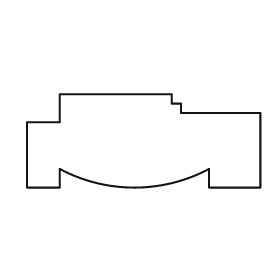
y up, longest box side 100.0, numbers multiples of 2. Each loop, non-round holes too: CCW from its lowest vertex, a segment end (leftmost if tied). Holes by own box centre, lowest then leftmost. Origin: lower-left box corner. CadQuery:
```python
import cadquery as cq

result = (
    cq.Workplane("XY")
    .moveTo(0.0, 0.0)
    .lineTo(14.0, 0.0)
    .lineTo(14.0, 8.0)
    .threePointArc((46.0, 0.0), (78.0, 8.0))
    .lineTo(78.0, 0.0)
    .lineTo(100.0, 0.0)
    .lineTo(100.0, 32.0)
    .lineTo(66.0, 32.0)
    .lineTo(66.0, 36.0)
    .lineTo(62.0, 36.0)
    .lineTo(62.0, 40.0)
    .lineTo(14.0, 40.0)
    .lineTo(14.0, 28.0)
    .lineTo(0.0, 28.0)
    .close()
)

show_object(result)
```